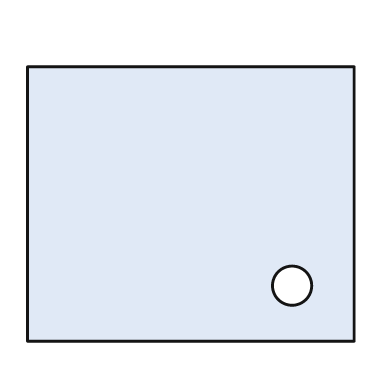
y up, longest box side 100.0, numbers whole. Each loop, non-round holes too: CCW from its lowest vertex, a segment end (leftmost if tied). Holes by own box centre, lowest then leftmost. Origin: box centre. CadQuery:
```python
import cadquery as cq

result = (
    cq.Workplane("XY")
    .moveTo(-50.0, -42.0)
    .lineTo(50.0, -42.0)
    .lineTo(50.0, 42.0)
    .lineTo(-50.0, 42.0)
    .close()
    .moveTo(31.0, -25.0)
    .circle(6.0)
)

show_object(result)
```